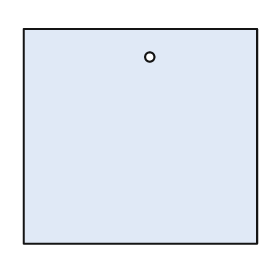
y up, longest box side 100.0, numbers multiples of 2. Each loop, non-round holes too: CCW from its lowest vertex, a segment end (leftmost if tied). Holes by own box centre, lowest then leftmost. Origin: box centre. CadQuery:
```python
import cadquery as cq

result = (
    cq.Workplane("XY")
    .moveTo(-50.0, -46.0)
    .lineTo(50.0, -46.0)
    .lineTo(50.0, 46.0)
    .lineTo(-50.0, 46.0)
    .close()
    .moveTo(4.0, 34.0)
    .circle(2.0)
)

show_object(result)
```